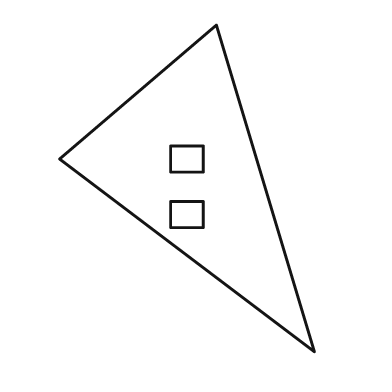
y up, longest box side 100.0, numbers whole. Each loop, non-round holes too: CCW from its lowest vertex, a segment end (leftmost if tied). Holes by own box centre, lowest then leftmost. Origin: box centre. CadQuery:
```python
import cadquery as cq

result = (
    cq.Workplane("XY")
    .moveTo(39.0, -50.0)
    .lineTo(9.0, 50.0)
    .lineTo(-39.0, 9.0)
    .close()
    .moveTo(-5.0, -12.0)
    .lineTo(5.0, -12.0)
    .lineTo(5.0, -4.0)
    .lineTo(-5.0, -4.0)
    .close()
    .moveTo(-5.0, 5.0)
    .lineTo(5.0, 5.0)
    .lineTo(5.0, 13.0)
    .lineTo(-5.0, 13.0)
    .close()
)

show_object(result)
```